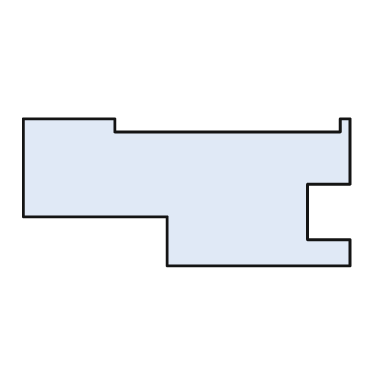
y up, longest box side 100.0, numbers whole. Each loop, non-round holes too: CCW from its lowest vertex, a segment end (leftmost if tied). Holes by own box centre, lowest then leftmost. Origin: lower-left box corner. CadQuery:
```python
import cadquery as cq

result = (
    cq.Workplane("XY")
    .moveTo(44.0, 0.0)
    .lineTo(100.0, 0.0)
    .lineTo(100.0, 8.0)
    .lineTo(87.0, 8.0)
    .lineTo(87.0, 25.0)
    .lineTo(100.0, 25.0)
    .lineTo(100.0, 45.0)
    .lineTo(97.0, 45.0)
    .lineTo(97.0, 41.0)
    .lineTo(28.0, 41.0)
    .lineTo(28.0, 45.0)
    .lineTo(0.0, 45.0)
    .lineTo(0.0, 15.0)
    .lineTo(44.0, 15.0)
    .close()
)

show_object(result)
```